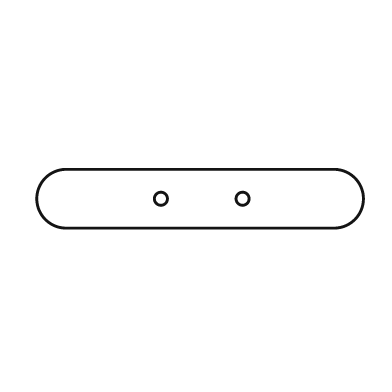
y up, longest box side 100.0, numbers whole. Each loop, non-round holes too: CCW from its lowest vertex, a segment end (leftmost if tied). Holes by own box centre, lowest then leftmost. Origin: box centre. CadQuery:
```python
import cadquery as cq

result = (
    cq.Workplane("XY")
    .moveTo(-41.0, -9.0)
    .lineTo(41.0, -9.0)
    .threePointArc((50.0, 0.0), (41.0, 9.0))
    .lineTo(-41.0, 9.0)
    .threePointArc((-50.0, 0.0), (-41.0, -9.0))
    .close()
    .moveTo(-12.0, 0.0)
    .circle(2.0)
    .moveTo(13.0, 0.0)
    .circle(2.0)
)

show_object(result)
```